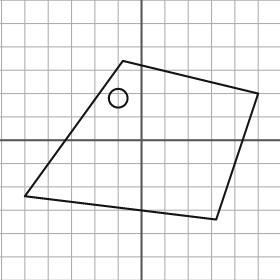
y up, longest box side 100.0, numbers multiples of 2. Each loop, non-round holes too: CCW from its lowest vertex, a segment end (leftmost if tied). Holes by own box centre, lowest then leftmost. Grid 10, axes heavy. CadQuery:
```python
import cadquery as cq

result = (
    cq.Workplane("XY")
    .moveTo(32.0, -34.0)
    .lineTo(50.0, 20.0)
    .lineTo(-8.0, 34.0)
    .lineTo(-50.0, -24.0)
    .close()
    .moveTo(-10.0, 18.0)
    .circle(4.0)
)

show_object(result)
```